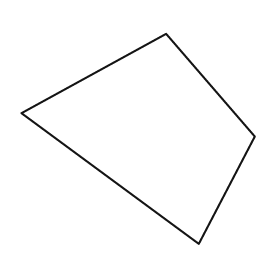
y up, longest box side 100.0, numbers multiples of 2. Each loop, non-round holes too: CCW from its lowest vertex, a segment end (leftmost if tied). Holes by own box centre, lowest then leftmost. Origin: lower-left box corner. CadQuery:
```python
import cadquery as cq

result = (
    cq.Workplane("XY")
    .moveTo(76.0, 0.0)
    .lineTo(100.0, 46.0)
    .lineTo(62.0, 90.0)
    .lineTo(0.0, 56.0)
    .close()
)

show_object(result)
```